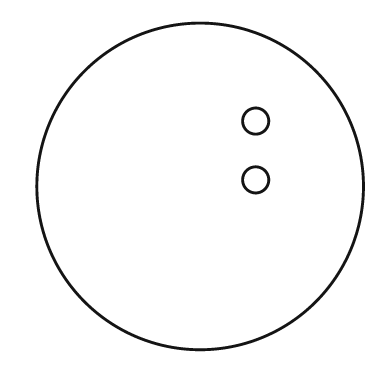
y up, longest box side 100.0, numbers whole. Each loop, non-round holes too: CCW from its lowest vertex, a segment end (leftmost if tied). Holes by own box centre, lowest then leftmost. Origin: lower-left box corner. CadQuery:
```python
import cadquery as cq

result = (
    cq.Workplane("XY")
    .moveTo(50.0, 50.0)
    .circle(50.0)
    .moveTo(67.0, 52.0)
    .circle(4.0)
    .moveTo(67.0, 70.0)
    .circle(4.0)
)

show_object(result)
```